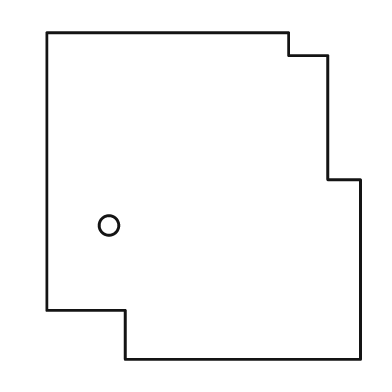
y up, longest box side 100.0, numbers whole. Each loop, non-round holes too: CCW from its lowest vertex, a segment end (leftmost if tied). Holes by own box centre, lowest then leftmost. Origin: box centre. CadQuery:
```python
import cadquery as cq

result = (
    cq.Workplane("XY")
    .moveTo(-24.0, -50.0)
    .lineTo(48.0, -50.0)
    .lineTo(48.0, 5.0)
    .lineTo(38.0, 5.0)
    .lineTo(38.0, 43.0)
    .lineTo(26.0, 43.0)
    .lineTo(26.0, 50.0)
    .lineTo(-48.0, 50.0)
    .lineTo(-48.0, -35.0)
    .lineTo(-24.0, -35.0)
    .close()
    .moveTo(-29.0, -9.0)
    .circle(3.0)
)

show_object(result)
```